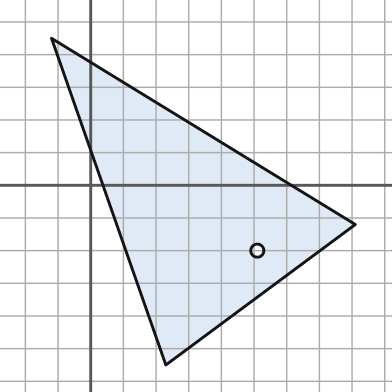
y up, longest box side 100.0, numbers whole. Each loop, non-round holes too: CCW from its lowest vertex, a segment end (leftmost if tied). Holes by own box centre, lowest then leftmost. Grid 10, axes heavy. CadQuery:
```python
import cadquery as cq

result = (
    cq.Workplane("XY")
    .moveTo(23.0, -55.0)
    .lineTo(81.0, -12.0)
    .lineTo(-12.0, 45.0)
    .close()
    .moveTo(51.0, -20.0)
    .circle(2.0)
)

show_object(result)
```